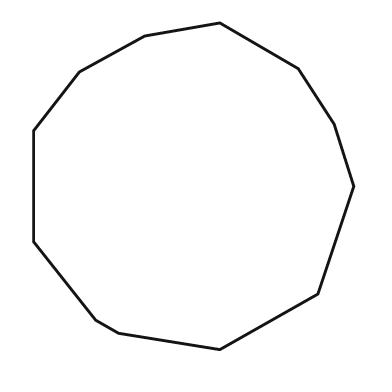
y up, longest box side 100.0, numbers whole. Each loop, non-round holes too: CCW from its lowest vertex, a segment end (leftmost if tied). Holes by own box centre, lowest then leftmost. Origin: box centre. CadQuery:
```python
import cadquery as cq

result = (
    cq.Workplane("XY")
    .moveTo(8.0, -50.0)
    .lineTo(38.0, -33.0)
    .lineTo(49.0, 0.0)
    .lineTo(43.0, 19.0)
    .lineTo(32.0, 36.0)
    .lineTo(8.0, 50.0)
    .lineTo(-15.0, 46.0)
    .lineTo(-35.0, 35.0)
    .lineTo(-49.0, 17.0)
    .lineTo(-49.0, -17.0)
    .lineTo(-30.0, -41.0)
    .lineTo(-23.0, -45.0)
    .close()
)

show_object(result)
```